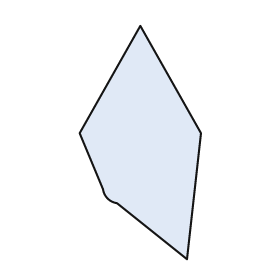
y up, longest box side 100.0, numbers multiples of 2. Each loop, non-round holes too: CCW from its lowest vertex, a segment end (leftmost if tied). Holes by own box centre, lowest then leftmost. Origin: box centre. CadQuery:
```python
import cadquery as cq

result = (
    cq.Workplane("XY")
    .moveTo(20.0, -50.0)
    .lineTo(26.0, 4.0)
    .lineTo(0.0, 50.0)
    .lineTo(-26.0, 4.0)
    .lineTo(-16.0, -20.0)
    .threePointArc((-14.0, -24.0), (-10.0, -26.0))
    .close()
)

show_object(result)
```